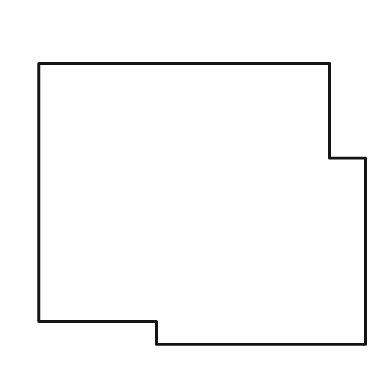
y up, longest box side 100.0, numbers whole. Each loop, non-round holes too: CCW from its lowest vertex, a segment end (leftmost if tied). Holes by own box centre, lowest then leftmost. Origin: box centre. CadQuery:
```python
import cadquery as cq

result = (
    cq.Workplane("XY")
    .moveTo(-14.0, -43.0)
    .lineTo(50.0, -43.0)
    .lineTo(50.0, 14.0)
    .lineTo(39.0, 14.0)
    .lineTo(39.0, 43.0)
    .lineTo(-50.0, 43.0)
    .lineTo(-50.0, -36.0)
    .lineTo(-14.0, -36.0)
    .close()
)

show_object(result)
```